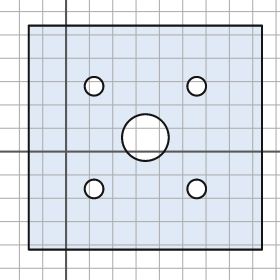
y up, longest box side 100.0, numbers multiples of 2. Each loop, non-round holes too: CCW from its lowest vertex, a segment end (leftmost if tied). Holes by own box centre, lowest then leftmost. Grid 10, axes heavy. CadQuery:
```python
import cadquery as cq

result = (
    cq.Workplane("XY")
    .moveTo(-16.0, -42.0)
    .lineTo(84.0, -42.0)
    .lineTo(84.0, 54.0)
    .lineTo(-16.0, 54.0)
    .close()
    .moveTo(12.0, -16.0)
    .circle(4.0)
    .moveTo(56.0, -16.0)
    .circle(4.0)
    .moveTo(34.0, 6.0)
    .circle(10.0)
    .moveTo(12.0, 28.0)
    .circle(4.0)
    .moveTo(56.0, 28.0)
    .circle(4.0)
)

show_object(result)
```